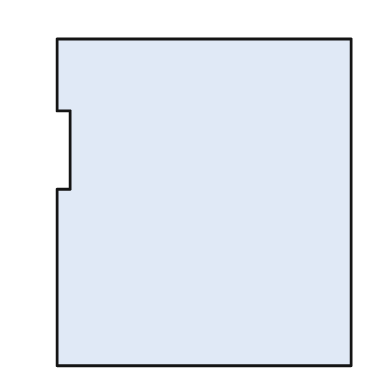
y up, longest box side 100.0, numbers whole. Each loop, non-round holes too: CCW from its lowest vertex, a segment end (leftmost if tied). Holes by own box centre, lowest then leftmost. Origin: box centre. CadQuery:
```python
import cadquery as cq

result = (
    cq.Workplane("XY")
    .moveTo(-45.0, -50.0)
    .lineTo(45.0, -50.0)
    .lineTo(45.0, 50.0)
    .lineTo(-45.0, 50.0)
    .lineTo(-45.0, 28.0)
    .lineTo(-41.0, 28.0)
    .lineTo(-41.0, 4.0)
    .lineTo(-45.0, 4.0)
    .close()
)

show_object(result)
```